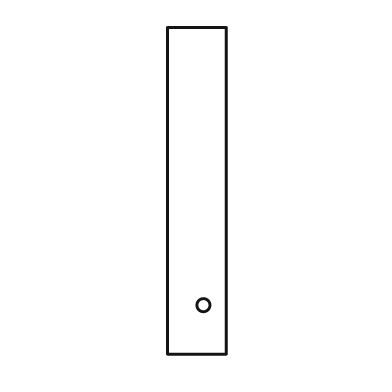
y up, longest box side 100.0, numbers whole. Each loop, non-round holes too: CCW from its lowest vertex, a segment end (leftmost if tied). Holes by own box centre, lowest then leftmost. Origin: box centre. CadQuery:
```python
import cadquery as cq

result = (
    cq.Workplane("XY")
    .moveTo(-9.0, -50.0)
    .lineTo(9.0, -50.0)
    .lineTo(9.0, 50.0)
    .lineTo(-9.0, 50.0)
    .close()
    .moveTo(2.0, -35.0)
    .circle(2.0)
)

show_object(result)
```